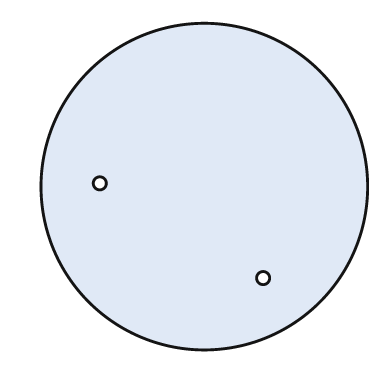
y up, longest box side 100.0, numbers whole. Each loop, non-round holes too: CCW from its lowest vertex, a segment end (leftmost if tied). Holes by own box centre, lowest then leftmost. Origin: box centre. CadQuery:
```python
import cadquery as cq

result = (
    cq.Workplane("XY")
    .moveTo(0.0, 0.0)
    .circle(50.0)
    .moveTo(18.0, -28.0)
    .circle(2.0)
    .moveTo(-32.0, 1.0)
    .circle(2.0)
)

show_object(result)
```